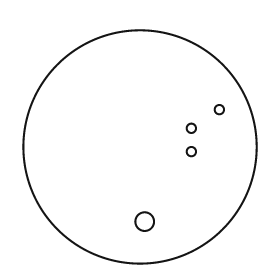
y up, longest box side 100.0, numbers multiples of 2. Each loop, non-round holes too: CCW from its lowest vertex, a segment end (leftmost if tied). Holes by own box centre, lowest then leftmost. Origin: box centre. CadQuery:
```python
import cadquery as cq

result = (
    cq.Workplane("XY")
    .moveTo(0.0, 0.0)
    .circle(50.0)
    .moveTo(2.0, -32.0)
    .circle(4.0)
    .moveTo(22.0, -2.0)
    .circle(2.0)
    .moveTo(22.0, 8.0)
    .circle(2.0)
    .moveTo(34.0, 16.0)
    .circle(2.0)
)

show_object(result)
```